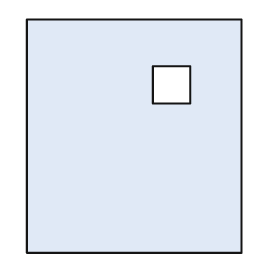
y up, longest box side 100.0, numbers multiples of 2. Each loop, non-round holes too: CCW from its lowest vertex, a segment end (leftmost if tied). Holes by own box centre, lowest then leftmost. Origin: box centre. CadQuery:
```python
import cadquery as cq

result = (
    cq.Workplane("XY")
    .moveTo(-46.0, -50.0)
    .lineTo(46.0, -50.0)
    .lineTo(46.0, 50.0)
    .lineTo(-46.0, 50.0)
    .close()
    .moveTo(8.0, 14.0)
    .lineTo(24.0, 14.0)
    .lineTo(24.0, 30.0)
    .lineTo(8.0, 30.0)
    .close()
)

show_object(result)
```